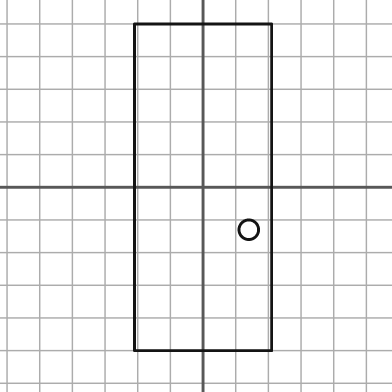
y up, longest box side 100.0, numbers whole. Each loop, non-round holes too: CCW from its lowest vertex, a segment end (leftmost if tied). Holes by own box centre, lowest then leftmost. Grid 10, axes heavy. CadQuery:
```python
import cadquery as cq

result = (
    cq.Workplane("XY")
    .moveTo(-21.0, -50.0)
    .lineTo(21.0, -50.0)
    .lineTo(21.0, 50.0)
    .lineTo(-21.0, 50.0)
    .close()
    .moveTo(14.0, -13.0)
    .circle(3.0)
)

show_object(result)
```